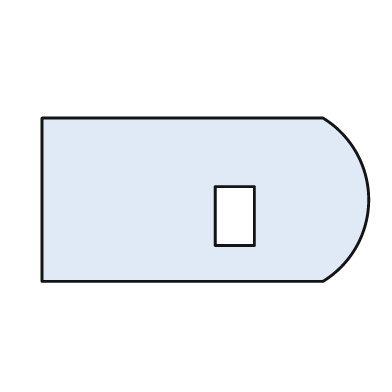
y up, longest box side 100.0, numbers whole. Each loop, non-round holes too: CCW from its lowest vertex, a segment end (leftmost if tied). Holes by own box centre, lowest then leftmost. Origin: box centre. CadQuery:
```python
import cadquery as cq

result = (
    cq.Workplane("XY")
    .moveTo(-50.0, -25.0)
    .lineTo(36.0, -25.0)
    .threePointArc((50.0, 0.0), (36.0, 25.0))
    .lineTo(-50.0, 25.0)
    .close()
    .moveTo(3.0, -14.0)
    .lineTo(15.0, -14.0)
    .lineTo(15.0, 4.0)
    .lineTo(3.0, 4.0)
    .close()
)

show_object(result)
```